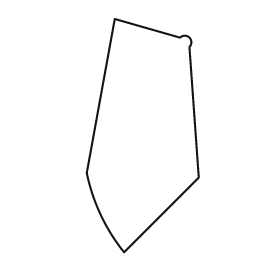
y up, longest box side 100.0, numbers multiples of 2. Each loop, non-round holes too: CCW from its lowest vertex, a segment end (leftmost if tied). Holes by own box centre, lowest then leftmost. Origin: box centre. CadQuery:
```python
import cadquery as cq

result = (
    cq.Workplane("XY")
    .moveTo(-8.0, -50.0)
    .lineTo(24.0, -18.0)
    .lineTo(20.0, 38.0)
    .threePointArc((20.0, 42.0), (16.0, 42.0))
    .lineTo(-12.0, 50.0)
    .lineTo(-24.0, -16.0)
    .threePointArc((-18.0, -34.0), (-8.0, -50.0))
    .close()
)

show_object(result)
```